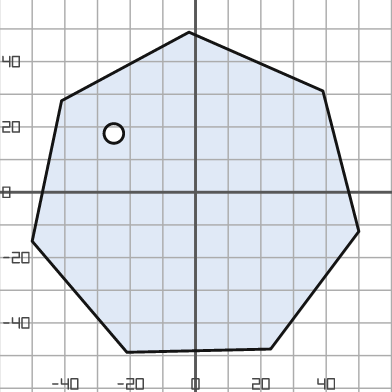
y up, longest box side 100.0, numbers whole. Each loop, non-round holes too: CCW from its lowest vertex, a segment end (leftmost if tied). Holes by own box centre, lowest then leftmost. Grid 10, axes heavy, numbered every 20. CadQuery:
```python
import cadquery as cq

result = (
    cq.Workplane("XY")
    .moveTo(-21.0, -49.0)
    .lineTo(23.0, -48.0)
    .lineTo(50.0, -12.0)
    .lineTo(39.0, 31.0)
    .lineTo(-2.0, 49.0)
    .lineTo(-41.0, 28.0)
    .lineTo(-50.0, -15.0)
    .close()
    .moveTo(-25.0, 18.0)
    .circle(3.0)
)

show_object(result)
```